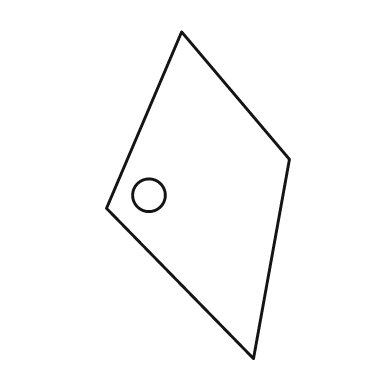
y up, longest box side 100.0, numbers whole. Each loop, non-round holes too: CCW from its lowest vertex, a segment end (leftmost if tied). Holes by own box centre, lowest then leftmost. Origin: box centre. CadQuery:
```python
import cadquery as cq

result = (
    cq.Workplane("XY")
    .moveTo(17.0, -50.0)
    .lineTo(28.0, 11.0)
    .lineTo(-5.0, 50.0)
    .lineTo(-28.0, -4.0)
    .close()
    .moveTo(-15.0, 0.0)
    .circle(5.0)
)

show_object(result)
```